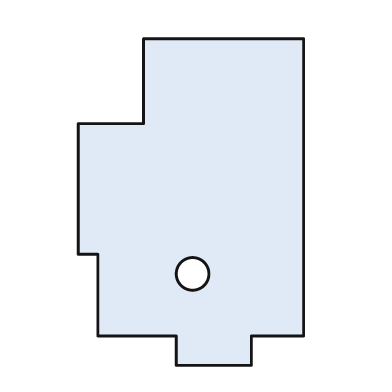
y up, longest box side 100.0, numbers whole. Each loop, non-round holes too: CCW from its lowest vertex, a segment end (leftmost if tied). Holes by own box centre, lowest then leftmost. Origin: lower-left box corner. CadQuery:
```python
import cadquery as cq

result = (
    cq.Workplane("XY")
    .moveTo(30.0, 0.0)
    .lineTo(53.0, 0.0)
    .lineTo(53.0, 9.0)
    .lineTo(69.0, 9.0)
    .lineTo(69.0, 100.0)
    .lineTo(20.0, 100.0)
    .lineTo(20.0, 74.0)
    .lineTo(0.0, 74.0)
    .lineTo(0.0, 34.0)
    .lineTo(6.0, 34.0)
    .lineTo(6.0, 9.0)
    .lineTo(30.0, 9.0)
    .close()
    .moveTo(35.0, 28.0)
    .circle(5.0)
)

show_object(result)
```